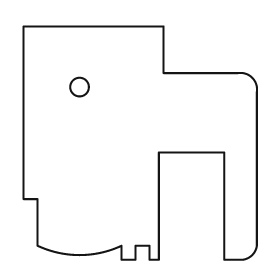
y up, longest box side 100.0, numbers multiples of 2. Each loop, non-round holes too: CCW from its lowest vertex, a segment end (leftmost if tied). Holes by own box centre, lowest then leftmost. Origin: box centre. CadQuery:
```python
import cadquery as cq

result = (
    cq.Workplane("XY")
    .moveTo(-8.0, -50.0)
    .lineTo(-2.0, -50.0)
    .lineTo(-2.0, -44.0)
    .lineTo(4.0, -44.0)
    .lineTo(4.0, -50.0)
    .lineTo(8.0, -50.0)
    .lineTo(8.0, -4.0)
    .lineTo(36.0, -4.0)
    .lineTo(36.0, -50.0)
    .lineTo(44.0, -50.0)
    .threePointArc((48.0, -48.0), (50.0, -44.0))
    .lineTo(50.0, 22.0)
    .threePointArc((48.0, 28.0), (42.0, 30.0))
    .lineTo(10.0, 30.0)
    .lineTo(10.0, 50.0)
    .lineTo(-50.0, 50.0)
    .lineTo(-50.0, -24.0)
    .lineTo(-44.0, -24.0)
    .lineTo(-44.0, -44.0)
    .threePointArc((-26.0, -48.0), (-8.0, -44.0))
    .close()
    .moveTo(-26.0, 24.0)
    .circle(4.0)
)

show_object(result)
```